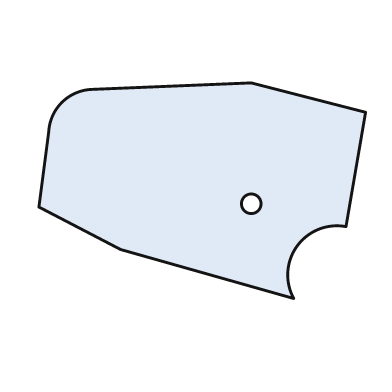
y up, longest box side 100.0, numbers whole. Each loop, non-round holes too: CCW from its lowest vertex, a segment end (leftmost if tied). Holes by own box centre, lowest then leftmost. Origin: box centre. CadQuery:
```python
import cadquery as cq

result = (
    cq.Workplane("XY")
    .moveTo(28.0, -33.0)
    .threePointArc((29.0, -17.0), (44.0, -11.0))
    .lineTo(50.0, 24.0)
    .lineTo(15.0, 33.0)
    .lineTo(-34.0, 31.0)
    .threePointArc((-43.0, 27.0), (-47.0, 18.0))
    .lineTo(-50.0, -5.0)
    .lineTo(-25.0, -18.0)
    .close()
    .moveTo(15.0, -4.0)
    .circle(3.0)
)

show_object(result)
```